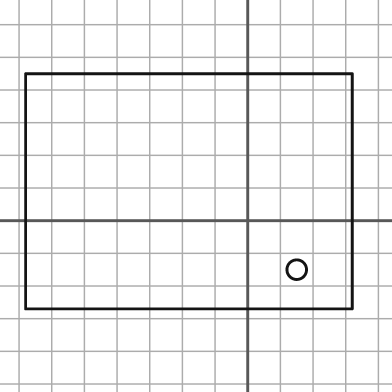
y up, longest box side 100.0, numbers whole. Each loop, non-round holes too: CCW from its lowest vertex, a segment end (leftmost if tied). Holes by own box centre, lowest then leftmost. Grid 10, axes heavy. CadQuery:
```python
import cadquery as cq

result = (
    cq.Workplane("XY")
    .moveTo(-68.0, -27.0)
    .lineTo(32.0, -27.0)
    .lineTo(32.0, 45.0)
    .lineTo(-68.0, 45.0)
    .close()
    .moveTo(15.0, -15.0)
    .circle(3.0)
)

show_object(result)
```